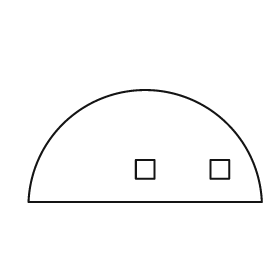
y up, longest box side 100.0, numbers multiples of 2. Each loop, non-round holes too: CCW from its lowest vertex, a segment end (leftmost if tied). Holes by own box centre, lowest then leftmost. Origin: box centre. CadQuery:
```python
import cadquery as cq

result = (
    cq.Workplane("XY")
    .moveTo(-50.0, -24.0)
    .lineTo(50.0, -24.0)
    .threePointArc((0.0, 24.0), (-50.0, -24.0))
    .close()
    .moveTo(-4.0, -14.0)
    .lineTo(4.0, -14.0)
    .lineTo(4.0, -6.0)
    .lineTo(-4.0, -6.0)
    .close()
    .moveTo(28.0, -14.0)
    .lineTo(36.0, -14.0)
    .lineTo(36.0, -6.0)
    .lineTo(28.0, -6.0)
    .close()
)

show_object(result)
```